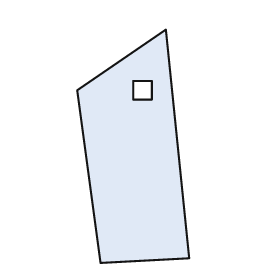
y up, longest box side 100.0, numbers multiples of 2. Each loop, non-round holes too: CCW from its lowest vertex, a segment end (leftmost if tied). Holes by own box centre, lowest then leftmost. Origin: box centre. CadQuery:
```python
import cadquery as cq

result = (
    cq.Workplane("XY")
    .moveTo(-14.0, -50.0)
    .lineTo(24.0, -48.0)
    .lineTo(14.0, 50.0)
    .lineTo(-24.0, 24.0)
    .close()
    .moveTo(0.0, 20.0)
    .lineTo(8.0, 20.0)
    .lineTo(8.0, 28.0)
    .lineTo(0.0, 28.0)
    .close()
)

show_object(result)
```